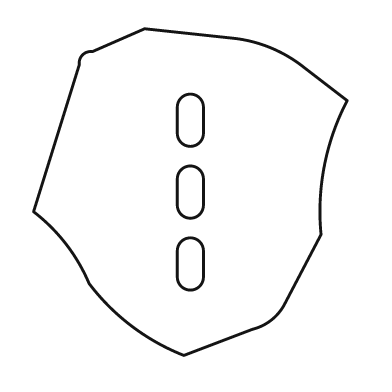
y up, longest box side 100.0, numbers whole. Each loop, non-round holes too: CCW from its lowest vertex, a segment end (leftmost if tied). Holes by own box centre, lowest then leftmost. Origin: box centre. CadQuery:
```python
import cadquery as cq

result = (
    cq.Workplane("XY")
    .moveTo(-2.0, -50.0)
    .lineTo(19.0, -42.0)
    .threePointArc((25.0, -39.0), (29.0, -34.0))
    .lineTo(40.0, -13.0)
    .threePointArc((41.0, 8.0), (48.0, 28.0))
    .lineTo(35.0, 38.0)
    .threePointArc((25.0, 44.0), (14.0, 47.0))
    .lineTo(-14.0, 50.0)
    .lineTo(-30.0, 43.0)
    .threePointArc((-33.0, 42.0), (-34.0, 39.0))
    .lineTo(-48.0, -6.0)
    .threePointArc((-38.0, -16.0), (-31.0, -28.0))
    .threePointArc((-18.0, -41.0), (-2.0, -50.0))
    .close()
    .moveTo(-4.0, -26.0)
    .threePointArc((0.0, -30.0), (4.0, -26.0))
    .lineTo(4.0, -18.0)
    .threePointArc((0.0, -14.0), (-4.0, -18.0))
    .close()
    .moveTo(-4.0, -4.0)
    .threePointArc((0.0, -8.0), (4.0, -4.0))
    .lineTo(4.0, 4.0)
    .threePointArc((0.0, 8.0), (-4.0, 4.0))
    .close()
    .moveTo(-4.0, 18.0)
    .threePointArc((0.0, 14.0), (4.0, 18.0))
    .lineTo(4.0, 26.0)
    .threePointArc((0.0, 30.0), (-4.0, 26.0))
    .close()
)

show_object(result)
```